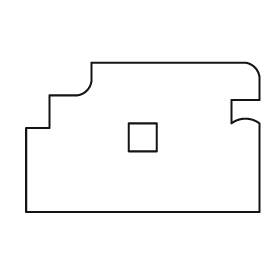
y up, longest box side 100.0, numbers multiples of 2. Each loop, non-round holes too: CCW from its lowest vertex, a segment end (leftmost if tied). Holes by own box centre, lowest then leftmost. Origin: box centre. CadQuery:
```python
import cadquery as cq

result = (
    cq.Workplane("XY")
    .moveTo(-50.0, -32.0)
    .lineTo(50.0, -32.0)
    .lineTo(50.0, 6.0)
    .threePointArc((44.0, 8.0), (38.0, 6.0))
    .lineTo(38.0, 16.0)
    .lineTo(50.0, 16.0)
    .lineTo(50.0, 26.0)
    .threePointArc((48.0, 30.0), (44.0, 32.0))
    .lineTo(-22.0, 32.0)
    .lineTo(-22.0, 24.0)
    .threePointArc((-24.0, 20.0), (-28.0, 18.0))
    .lineTo(-40.0, 18.0)
    .lineTo(-40.0, 4.0)
    .lineTo(-50.0, 4.0)
    .close()
    .moveTo(-6.0, -6.0)
    .lineTo(6.0, -6.0)
    .lineTo(6.0, 6.0)
    .lineTo(-6.0, 6.0)
    .close()
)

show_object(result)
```